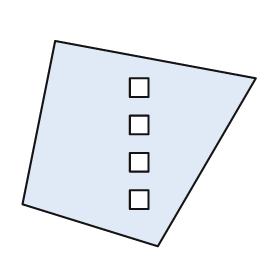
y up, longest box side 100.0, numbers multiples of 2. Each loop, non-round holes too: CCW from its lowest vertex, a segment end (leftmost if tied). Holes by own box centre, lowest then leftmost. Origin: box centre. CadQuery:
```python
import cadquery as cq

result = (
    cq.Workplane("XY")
    .moveTo(8.0, -44.0)
    .lineTo(50.0, 28.0)
    .lineTo(-36.0, 44.0)
    .lineTo(-50.0, -26.0)
    .close()
    .moveTo(-4.0, -28.0)
    .lineTo(4.0, -28.0)
    .lineTo(4.0, -20.0)
    .lineTo(-4.0, -20.0)
    .close()
    .moveTo(-4.0, -12.0)
    .lineTo(4.0, -12.0)
    .lineTo(4.0, -4.0)
    .lineTo(-4.0, -4.0)
    .close()
    .moveTo(-4.0, 4.0)
    .lineTo(4.0, 4.0)
    .lineTo(4.0, 12.0)
    .lineTo(-4.0, 12.0)
    .close()
    .moveTo(-4.0, 20.0)
    .lineTo(4.0, 20.0)
    .lineTo(4.0, 28.0)
    .lineTo(-4.0, 28.0)
    .close()
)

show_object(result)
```